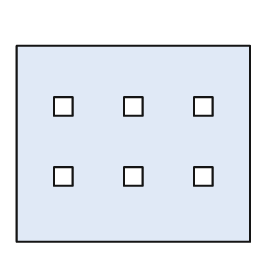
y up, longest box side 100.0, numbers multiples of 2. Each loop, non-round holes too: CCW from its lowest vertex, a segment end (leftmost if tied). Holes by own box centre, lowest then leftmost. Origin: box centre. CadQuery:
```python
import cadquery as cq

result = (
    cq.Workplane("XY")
    .moveTo(-50.0, -42.0)
    .lineTo(50.0, -42.0)
    .lineTo(50.0, 42.0)
    .lineTo(-50.0, 42.0)
    .close()
    .moveTo(-34.0, -18.0)
    .lineTo(-26.0, -18.0)
    .lineTo(-26.0, -10.0)
    .lineTo(-34.0, -10.0)
    .close()
    .moveTo(-4.0, -18.0)
    .lineTo(4.0, -18.0)
    .lineTo(4.0, -10.0)
    .lineTo(-4.0, -10.0)
    .close()
    .moveTo(26.0, -18.0)
    .lineTo(34.0, -18.0)
    .lineTo(34.0, -10.0)
    .lineTo(26.0, -10.0)
    .close()
    .moveTo(-34.0, 12.0)
    .lineTo(-26.0, 12.0)
    .lineTo(-26.0, 20.0)
    .lineTo(-34.0, 20.0)
    .close()
    .moveTo(-4.0, 12.0)
    .lineTo(4.0, 12.0)
    .lineTo(4.0, 20.0)
    .lineTo(-4.0, 20.0)
    .close()
    .moveTo(26.0, 12.0)
    .lineTo(34.0, 12.0)
    .lineTo(34.0, 20.0)
    .lineTo(26.0, 20.0)
    .close()
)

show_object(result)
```